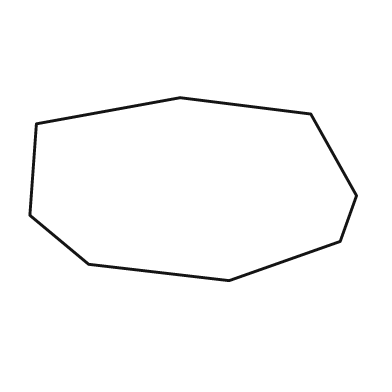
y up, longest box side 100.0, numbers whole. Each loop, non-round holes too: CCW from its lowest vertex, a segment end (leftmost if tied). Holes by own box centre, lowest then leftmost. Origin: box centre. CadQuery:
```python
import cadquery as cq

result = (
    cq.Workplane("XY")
    .moveTo(11.0, -28.0)
    .lineTo(45.0, -16.0)
    .lineTo(50.0, -2.0)
    .lineTo(36.0, 23.0)
    .lineTo(-4.0, 28.0)
    .lineTo(-48.0, 20.0)
    .lineTo(-50.0, -8.0)
    .lineTo(-32.0, -23.0)
    .close()
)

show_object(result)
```